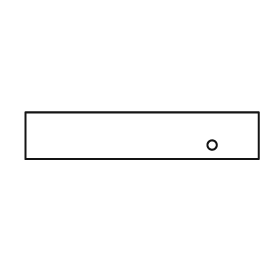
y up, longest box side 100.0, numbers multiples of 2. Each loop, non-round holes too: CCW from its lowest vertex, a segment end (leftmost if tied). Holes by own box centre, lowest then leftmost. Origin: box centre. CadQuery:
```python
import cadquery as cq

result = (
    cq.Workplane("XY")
    .moveTo(-50.0, -10.0)
    .lineTo(50.0, -10.0)
    .lineTo(50.0, 10.0)
    .lineTo(-50.0, 10.0)
    .close()
    .moveTo(30.0, -4.0)
    .circle(2.0)
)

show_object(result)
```